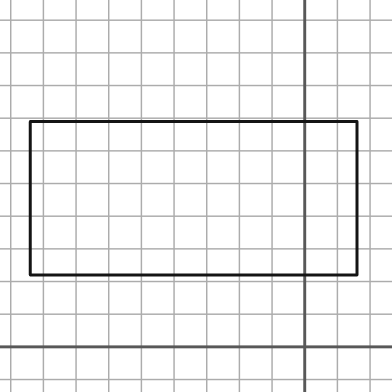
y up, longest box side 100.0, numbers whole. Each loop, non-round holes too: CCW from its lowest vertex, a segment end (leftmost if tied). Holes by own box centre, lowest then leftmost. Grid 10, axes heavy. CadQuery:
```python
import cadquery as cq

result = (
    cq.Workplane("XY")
    .moveTo(-84.0, 22.0)
    .lineTo(16.0, 22.0)
    .lineTo(16.0, 69.0)
    .lineTo(-84.0, 69.0)
    .close()
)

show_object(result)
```